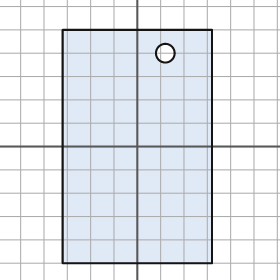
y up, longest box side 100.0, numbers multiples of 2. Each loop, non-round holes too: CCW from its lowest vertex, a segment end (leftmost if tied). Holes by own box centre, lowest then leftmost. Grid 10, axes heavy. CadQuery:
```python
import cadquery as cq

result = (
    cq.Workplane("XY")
    .moveTo(-32.0, -50.0)
    .lineTo(32.0, -50.0)
    .lineTo(32.0, 50.0)
    .lineTo(-32.0, 50.0)
    .close()
    .moveTo(12.0, 40.0)
    .circle(4.0)
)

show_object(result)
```